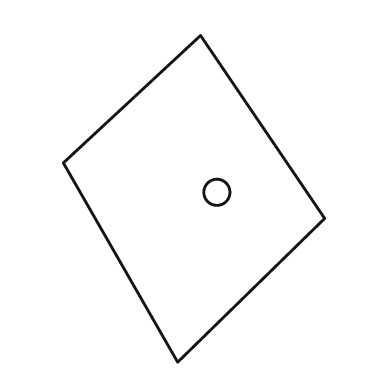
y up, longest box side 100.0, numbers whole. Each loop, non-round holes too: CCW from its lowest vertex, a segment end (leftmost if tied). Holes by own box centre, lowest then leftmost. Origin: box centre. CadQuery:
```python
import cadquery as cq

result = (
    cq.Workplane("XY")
    .moveTo(-5.0, -50.0)
    .lineTo(40.0, -6.0)
    .lineTo(2.0, 50.0)
    .lineTo(-40.0, 11.0)
    .close()
    .moveTo(7.0, 2.0)
    .circle(4.0)
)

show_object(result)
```